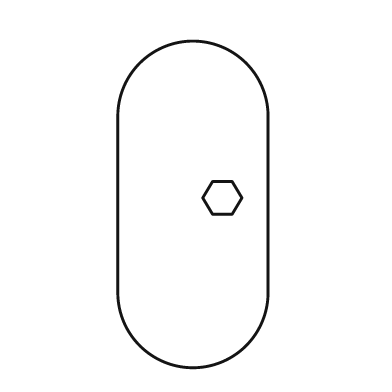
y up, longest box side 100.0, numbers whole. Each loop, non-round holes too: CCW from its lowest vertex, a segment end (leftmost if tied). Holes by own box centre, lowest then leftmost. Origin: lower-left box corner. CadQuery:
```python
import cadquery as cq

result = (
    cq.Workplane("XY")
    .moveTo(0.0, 23.0)
    .threePointArc((23.0, 0.0), (46.0, 23.0))
    .lineTo(46.0, 77.0)
    .threePointArc((23.0, 100.0), (0.0, 77.0))
    .close()
    .moveTo(29.0, 47.0)
    .lineTo(35.0, 47.0)
    .lineTo(38.0, 52.0)
    .lineTo(35.0, 57.0)
    .lineTo(29.0, 57.0)
    .lineTo(26.0, 52.0)
    .close()
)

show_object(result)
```